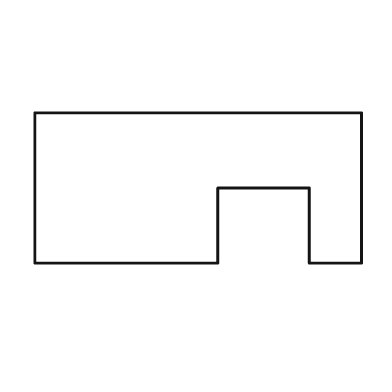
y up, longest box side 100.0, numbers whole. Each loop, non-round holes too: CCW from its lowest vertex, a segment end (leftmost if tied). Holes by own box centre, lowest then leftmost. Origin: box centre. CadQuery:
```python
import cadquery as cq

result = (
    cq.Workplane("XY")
    .moveTo(-50.0, -23.0)
    .lineTo(6.0, -23.0)
    .lineTo(6.0, 0.0)
    .lineTo(34.0, 0.0)
    .lineTo(34.0, -23.0)
    .lineTo(50.0, -23.0)
    .lineTo(50.0, 23.0)
    .lineTo(-50.0, 23.0)
    .close()
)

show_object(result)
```